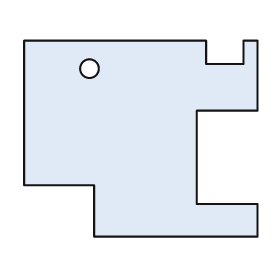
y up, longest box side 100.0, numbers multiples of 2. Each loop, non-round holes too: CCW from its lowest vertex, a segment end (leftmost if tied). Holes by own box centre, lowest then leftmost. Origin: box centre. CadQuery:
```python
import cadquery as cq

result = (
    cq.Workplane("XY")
    .moveTo(-20.0, -42.0)
    .lineTo(50.0, -42.0)
    .lineTo(50.0, -28.0)
    .lineTo(24.0, -28.0)
    .lineTo(24.0, 12.0)
    .lineTo(50.0, 12.0)
    .lineTo(50.0, 42.0)
    .lineTo(44.0, 42.0)
    .lineTo(44.0, 32.0)
    .lineTo(28.0, 32.0)
    .lineTo(28.0, 42.0)
    .lineTo(-50.0, 42.0)
    .lineTo(-50.0, -20.0)
    .lineTo(-20.0, -20.0)
    .close()
    .moveTo(-22.0, 30.0)
    .circle(4.0)
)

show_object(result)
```